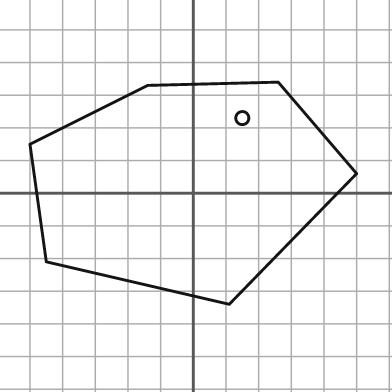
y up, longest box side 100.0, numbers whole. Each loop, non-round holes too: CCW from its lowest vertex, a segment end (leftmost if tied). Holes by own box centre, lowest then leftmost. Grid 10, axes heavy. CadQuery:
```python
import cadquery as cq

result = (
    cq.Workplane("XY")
    .moveTo(11.0, -34.0)
    .lineTo(50.0, 6.0)
    .lineTo(26.0, 34.0)
    .lineTo(-14.0, 33.0)
    .lineTo(-50.0, 15.0)
    .lineTo(-45.0, -21.0)
    .close()
    .moveTo(15.0, 23.0)
    .circle(2.0)
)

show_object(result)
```